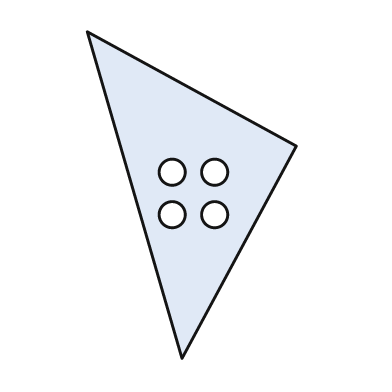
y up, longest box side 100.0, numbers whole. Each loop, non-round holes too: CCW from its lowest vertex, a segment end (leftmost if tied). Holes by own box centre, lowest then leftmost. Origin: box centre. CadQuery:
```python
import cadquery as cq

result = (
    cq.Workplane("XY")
    .moveTo(-3.0, -50.0)
    .lineTo(32.0, 15.0)
    .lineTo(-32.0, 50.0)
    .close()
    .moveTo(-6.0, -6.0)
    .circle(4.0)
    .moveTo(7.0, -6.0)
    .circle(4.0)
    .moveTo(-6.0, 7.0)
    .circle(4.0)
    .moveTo(7.0, 7.0)
    .circle(4.0)
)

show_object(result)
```